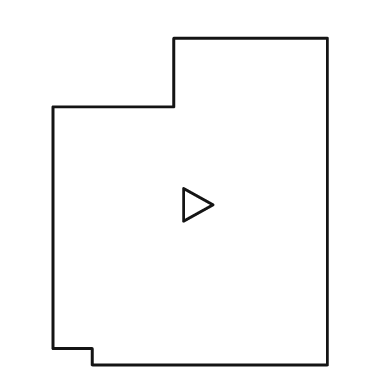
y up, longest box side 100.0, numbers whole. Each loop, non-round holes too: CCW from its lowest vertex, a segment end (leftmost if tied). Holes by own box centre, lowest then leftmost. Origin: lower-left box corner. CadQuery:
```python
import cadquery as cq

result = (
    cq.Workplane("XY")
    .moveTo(12.0, 0.0)
    .lineTo(84.0, 0.0)
    .lineTo(84.0, 100.0)
    .lineTo(37.0, 100.0)
    .lineTo(37.0, 79.0)
    .lineTo(0.0, 79.0)
    .lineTo(0.0, 5.0)
    .lineTo(12.0, 5.0)
    .close()
    .moveTo(40.0, 44.0)
    .lineTo(49.0, 49.0)
    .lineTo(40.0, 54.0)
    .close()
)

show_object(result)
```